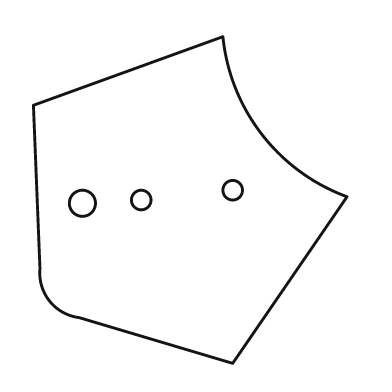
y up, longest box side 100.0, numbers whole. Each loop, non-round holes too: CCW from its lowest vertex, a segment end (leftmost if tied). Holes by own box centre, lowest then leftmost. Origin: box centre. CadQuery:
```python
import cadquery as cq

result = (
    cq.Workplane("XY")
    .moveTo(13.0, -50.0)
    .lineTo(48.0, 1.0)
    .threePointArc((22.0, 20.0), (10.0, 50.0))
    .lineTo(-48.0, 29.0)
    .lineTo(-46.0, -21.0)
    .threePointArc((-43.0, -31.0), (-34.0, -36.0))
    .close()
    .moveTo(-33.0, -1.0)
    .circle(4.0)
    .moveTo(-15.0, 0.0)
    .circle(3.0)
    .moveTo(13.0, 3.0)
    .circle(3.0)
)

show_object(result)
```